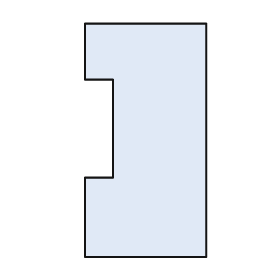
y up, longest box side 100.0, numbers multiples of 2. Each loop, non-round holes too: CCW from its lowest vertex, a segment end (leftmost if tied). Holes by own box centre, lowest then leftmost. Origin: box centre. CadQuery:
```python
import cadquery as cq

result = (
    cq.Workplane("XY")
    .moveTo(-26.0, -50.0)
    .lineTo(26.0, -50.0)
    .lineTo(26.0, 50.0)
    .lineTo(-26.0, 50.0)
    .lineTo(-26.0, 26.0)
    .lineTo(-14.0, 26.0)
    .lineTo(-14.0, -16.0)
    .lineTo(-26.0, -16.0)
    .close()
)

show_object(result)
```